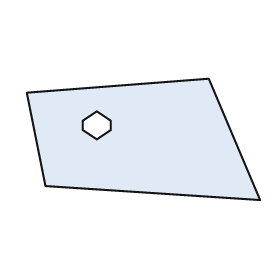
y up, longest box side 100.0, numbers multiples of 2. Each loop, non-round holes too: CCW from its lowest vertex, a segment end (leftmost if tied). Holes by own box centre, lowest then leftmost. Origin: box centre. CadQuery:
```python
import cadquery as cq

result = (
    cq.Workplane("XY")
    .moveTo(50.0, -26.0)
    .lineTo(28.0, 26.0)
    .lineTo(-50.0, 20.0)
    .lineTo(-42.0, -20.0)
    .close()
    .moveTo(-20.0, 0.0)
    .lineTo(-14.0, 4.0)
    .lineTo(-14.0, 8.0)
    .lineTo(-20.0, 12.0)
    .lineTo(-26.0, 8.0)
    .lineTo(-26.0, 4.0)
    .close()
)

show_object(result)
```